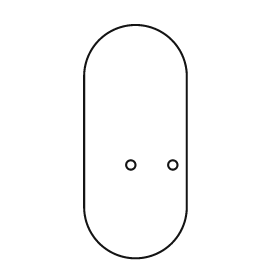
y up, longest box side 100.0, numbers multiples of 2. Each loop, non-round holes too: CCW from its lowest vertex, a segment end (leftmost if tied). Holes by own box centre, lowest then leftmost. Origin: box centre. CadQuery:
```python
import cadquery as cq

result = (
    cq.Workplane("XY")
    .moveTo(-22.0, -28.0)
    .threePointArc((0.0, -50.0), (22.0, -28.0))
    .lineTo(22.0, 28.0)
    .threePointArc((0.0, 50.0), (-22.0, 28.0))
    .close()
    .moveTo(-2.0, -10.0)
    .circle(2.0)
    .moveTo(16.0, -10.0)
    .circle(2.0)
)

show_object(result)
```